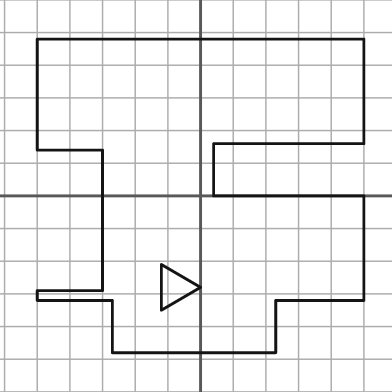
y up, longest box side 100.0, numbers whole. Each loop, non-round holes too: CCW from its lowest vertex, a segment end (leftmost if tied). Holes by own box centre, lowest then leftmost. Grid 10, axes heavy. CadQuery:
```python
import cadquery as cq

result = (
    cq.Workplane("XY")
    .moveTo(-27.0, -48.0)
    .lineTo(23.0, -48.0)
    .lineTo(23.0, -32.0)
    .lineTo(50.0, -32.0)
    .lineTo(50.0, 0.0)
    .lineTo(4.0, 0.0)
    .lineTo(4.0, 16.0)
    .lineTo(50.0, 16.0)
    .lineTo(50.0, 48.0)
    .lineTo(-50.0, 48.0)
    .lineTo(-50.0, 14.0)
    .lineTo(-30.0, 14.0)
    .lineTo(-30.0, -29.0)
    .lineTo(-50.0, -29.0)
    .lineTo(-50.0, -32.0)
    .lineTo(-27.0, -32.0)
    .close()
    .moveTo(-12.0, -35.0)
    .lineTo(0.0, -28.0)
    .lineTo(-12.0, -21.0)
    .close()
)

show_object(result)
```